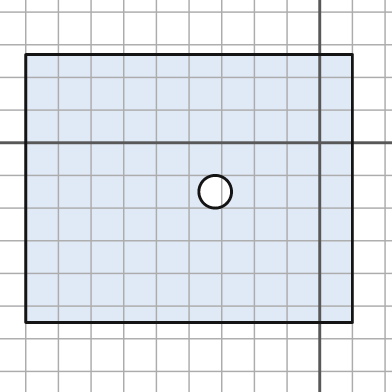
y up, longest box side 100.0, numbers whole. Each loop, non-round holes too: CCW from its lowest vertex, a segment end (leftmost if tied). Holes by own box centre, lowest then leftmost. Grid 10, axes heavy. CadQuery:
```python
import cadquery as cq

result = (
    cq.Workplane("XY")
    .moveTo(-90.0, -55.0)
    .lineTo(10.0, -55.0)
    .lineTo(10.0, 27.0)
    .lineTo(-90.0, 27.0)
    .close()
    .moveTo(-32.0, -15.0)
    .circle(5.0)
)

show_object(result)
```